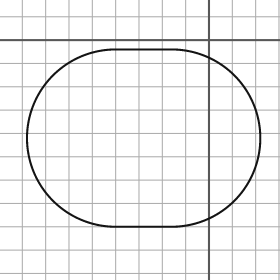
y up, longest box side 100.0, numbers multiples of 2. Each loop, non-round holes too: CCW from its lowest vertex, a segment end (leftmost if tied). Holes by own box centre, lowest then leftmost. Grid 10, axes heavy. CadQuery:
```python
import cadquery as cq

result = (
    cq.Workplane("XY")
    .moveTo(-40.0, -80.0)
    .lineTo(-16.0, -80.0)
    .threePointArc((22.0, -42.0), (-16.0, -4.0))
    .lineTo(-40.0, -4.0)
    .threePointArc((-78.0, -42.0), (-40.0, -80.0))
    .close()
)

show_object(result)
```